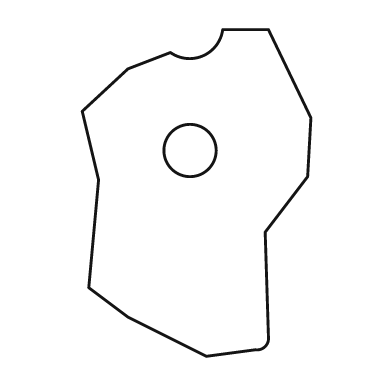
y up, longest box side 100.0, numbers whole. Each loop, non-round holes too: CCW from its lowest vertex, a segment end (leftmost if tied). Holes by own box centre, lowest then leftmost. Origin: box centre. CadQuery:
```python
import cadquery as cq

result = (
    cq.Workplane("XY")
    .moveTo(3.0, -50.0)
    .lineTo(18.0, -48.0)
    .threePointArc((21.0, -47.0), (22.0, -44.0))
    .lineTo(21.0, -12.0)
    .lineTo(34.0, 5.0)
    .lineTo(35.0, 23.0)
    .lineTo(22.0, 50.0)
    .lineTo(8.0, 50.0)
    .threePointArc((2.0, 42.0), (-8.0, 43.0))
    .lineTo(-21.0, 38.0)
    .lineTo(-35.0, 25.0)
    .lineTo(-30.0, 4.0)
    .lineTo(-33.0, -29.0)
    .lineTo(-21.0, -38.0)
    .close()
    .moveTo(-2.0, 13.0)
    .circle(8.0)
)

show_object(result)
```